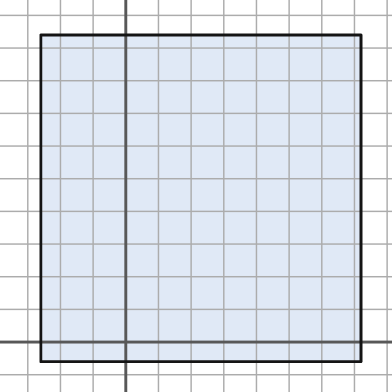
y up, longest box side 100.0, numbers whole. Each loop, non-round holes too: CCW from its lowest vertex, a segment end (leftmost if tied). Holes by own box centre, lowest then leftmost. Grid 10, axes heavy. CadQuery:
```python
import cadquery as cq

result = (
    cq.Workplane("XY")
    .moveTo(-26.0, -6.0)
    .lineTo(72.0, -6.0)
    .lineTo(72.0, 94.0)
    .lineTo(-26.0, 94.0)
    .close()
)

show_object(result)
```